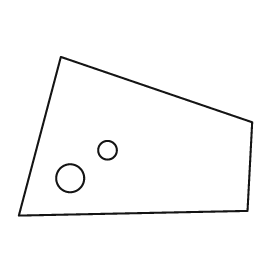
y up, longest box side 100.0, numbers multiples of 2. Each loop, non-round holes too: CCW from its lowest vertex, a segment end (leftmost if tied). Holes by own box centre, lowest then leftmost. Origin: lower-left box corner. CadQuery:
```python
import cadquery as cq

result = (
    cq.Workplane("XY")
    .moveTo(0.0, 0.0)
    .lineTo(98.0, 2.0)
    .lineTo(100.0, 40.0)
    .lineTo(18.0, 68.0)
    .close()
    .moveTo(22.0, 16.0)
    .circle(6.0)
    .moveTo(38.0, 28.0)
    .circle(4.0)
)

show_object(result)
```